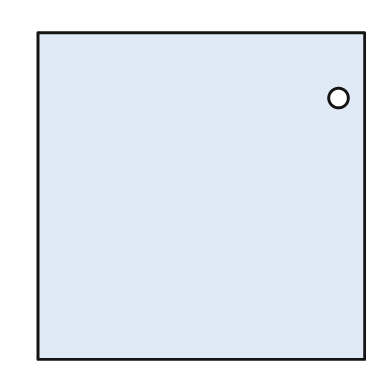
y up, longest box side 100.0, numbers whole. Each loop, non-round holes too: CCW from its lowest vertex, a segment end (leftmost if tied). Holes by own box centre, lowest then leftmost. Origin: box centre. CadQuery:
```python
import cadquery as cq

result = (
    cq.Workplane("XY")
    .moveTo(-50.0, -50.0)
    .lineTo(50.0, -50.0)
    .lineTo(50.0, 50.0)
    .lineTo(-50.0, 50.0)
    .close()
    .moveTo(42.0, 30.0)
    .circle(3.0)
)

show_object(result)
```